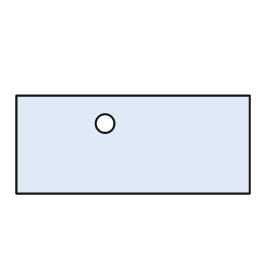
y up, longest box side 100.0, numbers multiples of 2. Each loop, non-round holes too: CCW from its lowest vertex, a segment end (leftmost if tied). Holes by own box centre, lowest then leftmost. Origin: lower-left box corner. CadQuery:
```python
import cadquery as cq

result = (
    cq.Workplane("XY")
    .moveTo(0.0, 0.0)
    .lineTo(100.0, 0.0)
    .lineTo(100.0, 42.0)
    .lineTo(0.0, 42.0)
    .close()
    .moveTo(38.0, 30.0)
    .circle(4.0)
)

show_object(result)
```